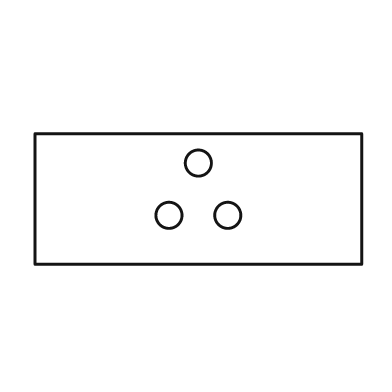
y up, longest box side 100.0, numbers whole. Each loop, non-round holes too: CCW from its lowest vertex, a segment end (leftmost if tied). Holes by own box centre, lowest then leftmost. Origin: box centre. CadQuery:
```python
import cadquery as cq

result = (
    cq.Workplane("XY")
    .moveTo(-50.0, -20.0)
    .lineTo(50.0, -20.0)
    .lineTo(50.0, 20.0)
    .lineTo(-50.0, 20.0)
    .close()
    .moveTo(-9.0, -5.0)
    .circle(4.0)
    .moveTo(9.0, -5.0)
    .circle(4.0)
    .moveTo(0.0, 11.0)
    .circle(4.0)
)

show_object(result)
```